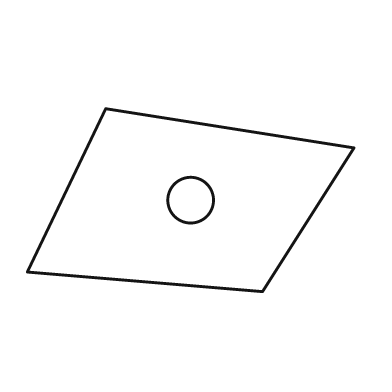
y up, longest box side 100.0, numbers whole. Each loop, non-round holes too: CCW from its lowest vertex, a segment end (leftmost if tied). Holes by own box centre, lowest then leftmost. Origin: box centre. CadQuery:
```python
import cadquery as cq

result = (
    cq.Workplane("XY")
    .moveTo(22.0, -28.0)
    .lineTo(50.0, 16.0)
    .lineTo(-26.0, 28.0)
    .lineTo(-50.0, -22.0)
    .close()
    .moveTo(0.0, 0.0)
    .circle(7.0)
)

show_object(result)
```